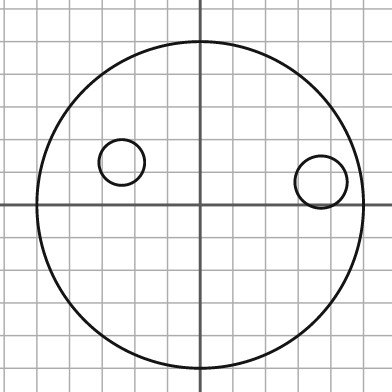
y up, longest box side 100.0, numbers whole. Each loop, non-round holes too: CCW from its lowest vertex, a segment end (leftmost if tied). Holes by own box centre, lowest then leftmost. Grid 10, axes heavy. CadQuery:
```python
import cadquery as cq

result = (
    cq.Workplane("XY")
    .moveTo(0.0, 0.0)
    .circle(50.0)
    .moveTo(37.0, 7.0)
    .circle(8.0)
    .moveTo(-24.0, 13.0)
    .circle(7.0)
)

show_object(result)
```